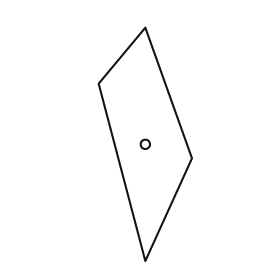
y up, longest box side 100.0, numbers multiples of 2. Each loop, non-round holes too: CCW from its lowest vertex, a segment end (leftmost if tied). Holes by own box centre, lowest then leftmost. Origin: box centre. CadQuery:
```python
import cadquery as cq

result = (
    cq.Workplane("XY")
    .moveTo(0.0, -50.0)
    .lineTo(20.0, -6.0)
    .lineTo(0.0, 50.0)
    .lineTo(-20.0, 26.0)
    .close()
    .moveTo(0.0, 0.0)
    .circle(2.0)
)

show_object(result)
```